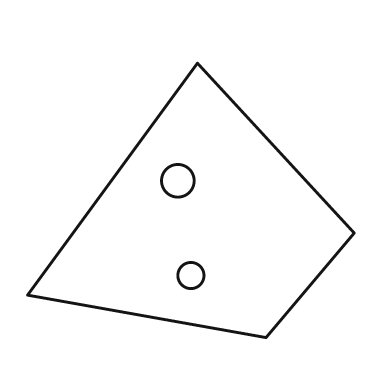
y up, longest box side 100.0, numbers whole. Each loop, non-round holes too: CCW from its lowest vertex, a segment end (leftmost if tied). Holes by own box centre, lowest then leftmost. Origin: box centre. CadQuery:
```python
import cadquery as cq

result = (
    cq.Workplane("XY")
    .moveTo(23.0, -42.0)
    .lineTo(50.0, -10.0)
    .lineTo(2.0, 42.0)
    .lineTo(-50.0, -29.0)
    .close()
    .moveTo(0.0, -23.0)
    .circle(4.0)
    .moveTo(-4.0, 6.0)
    .circle(5.0)
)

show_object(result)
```